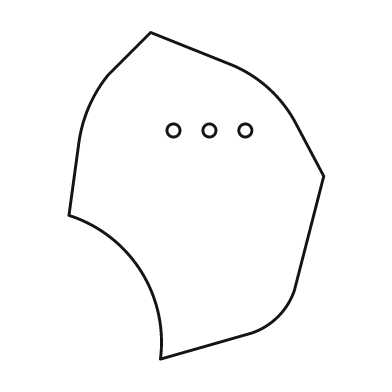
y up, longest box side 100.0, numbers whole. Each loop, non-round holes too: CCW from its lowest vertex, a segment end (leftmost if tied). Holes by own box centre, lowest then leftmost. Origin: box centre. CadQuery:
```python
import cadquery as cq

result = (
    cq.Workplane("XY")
    .moveTo(-11.0, -50.0)
    .lineTo(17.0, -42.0)
    .threePointArc((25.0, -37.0), (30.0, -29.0))
    .lineTo(39.0, 6.0)
    .lineTo(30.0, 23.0)
    .threePointArc((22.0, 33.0), (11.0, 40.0))
    .lineTo(-14.0, 50.0)
    .lineTo(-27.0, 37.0)
    .threePointArc((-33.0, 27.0), (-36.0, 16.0))
    .lineTo(-39.0, -6.0)
    .threePointArc((-17.0, -23.0), (-11.0, -50.0))
    .close()
    .moveTo(-7.0, 20.0)
    .circle(2.0)
    .moveTo(4.0, 20.0)
    .circle(2.0)
    .moveTo(15.0, 20.0)
    .circle(2.0)
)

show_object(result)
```